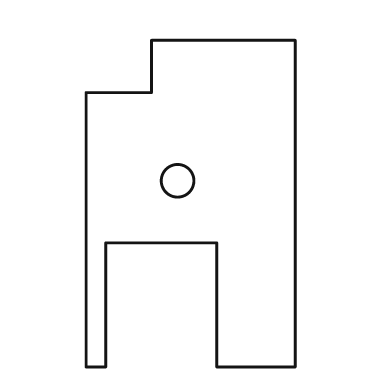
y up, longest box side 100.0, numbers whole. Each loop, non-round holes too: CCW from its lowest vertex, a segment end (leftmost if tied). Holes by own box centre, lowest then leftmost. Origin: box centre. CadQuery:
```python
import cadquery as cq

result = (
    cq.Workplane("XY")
    .moveTo(-32.0, -50.0)
    .lineTo(-26.0, -50.0)
    .lineTo(-26.0, -12.0)
    .lineTo(8.0, -12.0)
    .lineTo(8.0, -50.0)
    .lineTo(32.0, -50.0)
    .lineTo(32.0, 50.0)
    .lineTo(-12.0, 50.0)
    .lineTo(-12.0, 34.0)
    .lineTo(-32.0, 34.0)
    .close()
    .moveTo(-4.0, 7.0)
    .circle(5.0)
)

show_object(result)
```